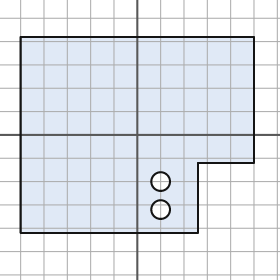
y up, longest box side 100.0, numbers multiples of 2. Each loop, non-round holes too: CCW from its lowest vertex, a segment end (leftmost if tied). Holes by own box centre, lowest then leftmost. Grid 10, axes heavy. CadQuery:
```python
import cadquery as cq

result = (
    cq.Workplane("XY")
    .moveTo(-50.0, -42.0)
    .lineTo(26.0, -42.0)
    .lineTo(26.0, -12.0)
    .lineTo(50.0, -12.0)
    .lineTo(50.0, 42.0)
    .lineTo(-50.0, 42.0)
    .close()
    .moveTo(10.0, -32.0)
    .circle(4.0)
    .moveTo(10.0, -20.0)
    .circle(4.0)
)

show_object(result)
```